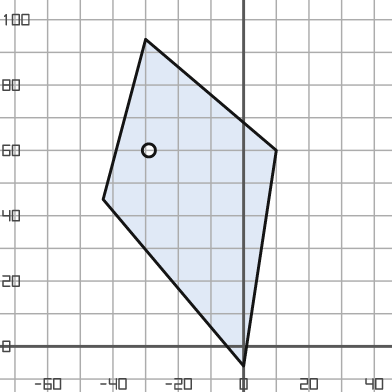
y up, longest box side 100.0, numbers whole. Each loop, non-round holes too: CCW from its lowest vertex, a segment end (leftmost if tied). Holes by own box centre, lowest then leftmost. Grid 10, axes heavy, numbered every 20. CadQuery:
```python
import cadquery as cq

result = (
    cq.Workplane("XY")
    .moveTo(0.0, -6.0)
    .lineTo(10.0, 60.0)
    .lineTo(-30.0, 94.0)
    .lineTo(-43.0, 45.0)
    .close()
    .moveTo(-29.0, 60.0)
    .circle(2.0)
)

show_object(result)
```